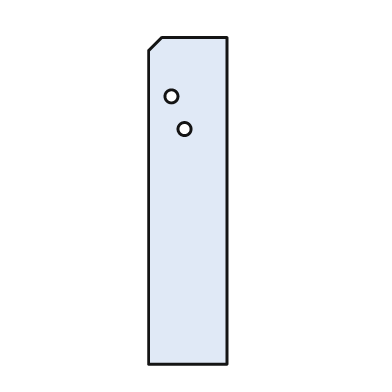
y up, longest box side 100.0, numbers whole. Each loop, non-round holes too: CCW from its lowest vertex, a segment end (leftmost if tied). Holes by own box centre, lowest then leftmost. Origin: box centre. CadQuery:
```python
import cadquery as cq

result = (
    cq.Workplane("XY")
    .moveTo(-12.0, -50.0)
    .lineTo(12.0, -50.0)
    .lineTo(12.0, 50.0)
    .lineTo(-8.0, 50.0)
    .lineTo(-12.0, 46.0)
    .close()
    .moveTo(-1.0, 22.0)
    .circle(2.0)
    .moveTo(-5.0, 32.0)
    .circle(2.0)
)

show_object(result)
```